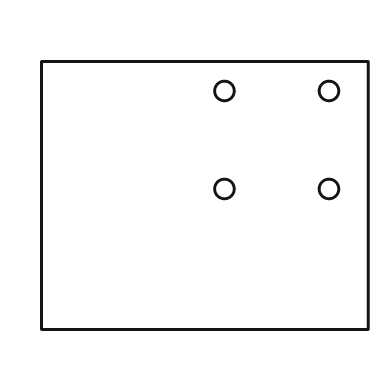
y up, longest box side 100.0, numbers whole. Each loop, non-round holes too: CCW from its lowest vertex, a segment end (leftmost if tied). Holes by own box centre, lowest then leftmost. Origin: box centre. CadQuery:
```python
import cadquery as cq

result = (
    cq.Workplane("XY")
    .moveTo(-50.0, -41.0)
    .lineTo(50.0, -41.0)
    .lineTo(50.0, 41.0)
    .lineTo(-50.0, 41.0)
    .close()
    .moveTo(6.0, 2.0)
    .circle(3.0)
    .moveTo(38.0, 2.0)
    .circle(3.0)
    .moveTo(6.0, 32.0)
    .circle(3.0)
    .moveTo(38.0, 32.0)
    .circle(3.0)
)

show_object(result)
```